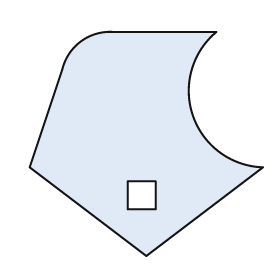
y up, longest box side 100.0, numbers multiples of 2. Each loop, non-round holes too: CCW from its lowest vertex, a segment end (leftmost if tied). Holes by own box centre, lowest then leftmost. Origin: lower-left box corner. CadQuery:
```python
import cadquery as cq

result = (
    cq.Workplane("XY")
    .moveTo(50.0, 0.0)
    .lineTo(100.0, 38.0)
    .threePointArc((70.0, 60.0), (80.0, 96.0))
    .lineTo(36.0, 96.0)
    .threePointArc((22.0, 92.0), (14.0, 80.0))
    .lineTo(0.0, 38.0)
    .close()
    .moveTo(42.0, 20.0)
    .lineTo(54.0, 20.0)
    .lineTo(54.0, 32.0)
    .lineTo(42.0, 32.0)
    .close()
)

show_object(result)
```